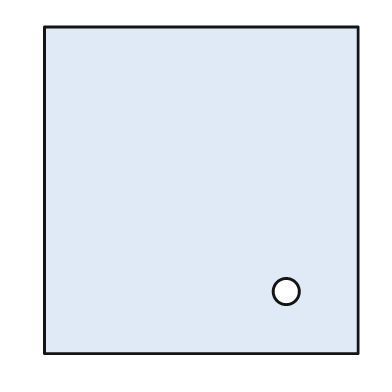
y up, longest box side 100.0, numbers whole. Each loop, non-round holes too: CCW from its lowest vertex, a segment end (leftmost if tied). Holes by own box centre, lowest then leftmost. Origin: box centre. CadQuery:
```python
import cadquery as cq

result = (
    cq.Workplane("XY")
    .moveTo(-48.0, -50.0)
    .lineTo(48.0, -50.0)
    .lineTo(48.0, 50.0)
    .lineTo(-48.0, 50.0)
    .close()
    .moveTo(26.0, -31.0)
    .circle(4.0)
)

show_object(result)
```